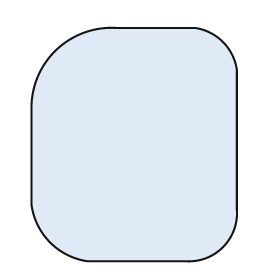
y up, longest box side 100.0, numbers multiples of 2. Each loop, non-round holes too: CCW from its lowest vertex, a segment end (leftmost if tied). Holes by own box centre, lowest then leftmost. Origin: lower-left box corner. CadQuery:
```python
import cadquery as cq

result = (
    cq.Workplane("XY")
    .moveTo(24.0, 0.0)
    .lineTo(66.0, 0.0)
    .threePointArc((82.0, 6.0), (88.0, 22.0))
    .lineTo(88.0, 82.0)
    .threePointArc((82.0, 94.0), (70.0, 100.0))
    .lineTo(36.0, 100.0)
    .threePointArc((10.0, 90.0), (0.0, 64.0))
    .lineTo(0.0, 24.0)
    .threePointArc((8.0, 8.0), (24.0, 0.0))
    .close()
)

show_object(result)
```